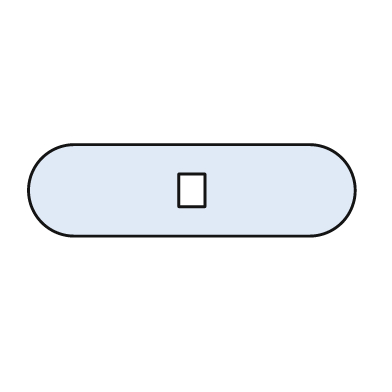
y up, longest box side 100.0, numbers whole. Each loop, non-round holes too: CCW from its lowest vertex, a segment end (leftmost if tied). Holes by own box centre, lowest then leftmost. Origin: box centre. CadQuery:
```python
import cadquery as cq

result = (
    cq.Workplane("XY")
    .moveTo(-36.0, -14.0)
    .lineTo(36.0, -14.0)
    .threePointArc((50.0, 0.0), (36.0, 14.0))
    .lineTo(-36.0, 14.0)
    .threePointArc((-50.0, 0.0), (-36.0, -14.0))
    .close()
    .moveTo(-4.0, -5.0)
    .lineTo(4.0, -5.0)
    .lineTo(4.0, 5.0)
    .lineTo(-4.0, 5.0)
    .close()
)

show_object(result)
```